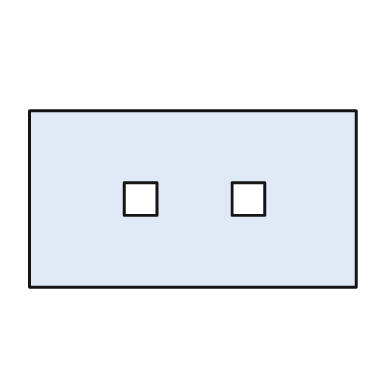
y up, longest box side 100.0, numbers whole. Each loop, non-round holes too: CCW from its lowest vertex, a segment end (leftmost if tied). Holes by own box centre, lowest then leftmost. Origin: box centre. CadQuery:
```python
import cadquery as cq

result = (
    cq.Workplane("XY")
    .moveTo(-50.0, -27.0)
    .lineTo(50.0, -27.0)
    .lineTo(50.0, 27.0)
    .lineTo(-50.0, 27.0)
    .close()
    .moveTo(-21.0, -5.0)
    .lineTo(-11.0, -5.0)
    .lineTo(-11.0, 5.0)
    .lineTo(-21.0, 5.0)
    .close()
    .moveTo(12.0, -5.0)
    .lineTo(22.0, -5.0)
    .lineTo(22.0, 5.0)
    .lineTo(12.0, 5.0)
    .close()
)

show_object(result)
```